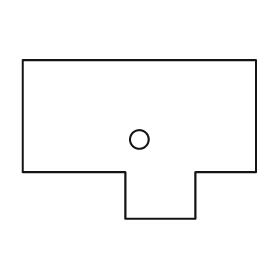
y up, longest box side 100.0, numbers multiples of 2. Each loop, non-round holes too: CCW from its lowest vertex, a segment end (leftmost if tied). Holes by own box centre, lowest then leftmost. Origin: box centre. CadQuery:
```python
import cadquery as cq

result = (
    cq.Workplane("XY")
    .moveTo(-6.0, -34.0)
    .lineTo(24.0, -34.0)
    .lineTo(24.0, -14.0)
    .lineTo(50.0, -14.0)
    .lineTo(50.0, 34.0)
    .lineTo(-50.0, 34.0)
    .lineTo(-50.0, -14.0)
    .lineTo(-6.0, -14.0)
    .close()
    .moveTo(0.0, 0.0)
    .circle(4.0)
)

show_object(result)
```